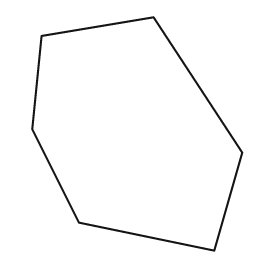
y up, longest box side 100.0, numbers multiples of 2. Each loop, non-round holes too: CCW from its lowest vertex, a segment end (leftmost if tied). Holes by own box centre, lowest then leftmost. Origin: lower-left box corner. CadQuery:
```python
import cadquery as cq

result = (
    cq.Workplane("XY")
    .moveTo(78.0, 0.0)
    .lineTo(90.0, 42.0)
    .lineTo(52.0, 100.0)
    .lineTo(4.0, 92.0)
    .lineTo(0.0, 52.0)
    .lineTo(20.0, 12.0)
    .close()
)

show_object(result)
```